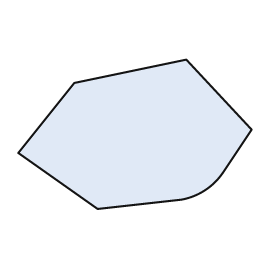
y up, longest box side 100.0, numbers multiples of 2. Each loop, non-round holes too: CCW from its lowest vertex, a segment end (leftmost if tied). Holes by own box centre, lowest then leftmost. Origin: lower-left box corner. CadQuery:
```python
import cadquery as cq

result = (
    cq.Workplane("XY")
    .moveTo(34.0, 0.0)
    .lineTo(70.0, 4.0)
    .threePointArc((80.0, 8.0), (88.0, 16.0))
    .lineTo(100.0, 34.0)
    .lineTo(72.0, 64.0)
    .lineTo(24.0, 54.0)
    .lineTo(0.0, 24.0)
    .close()
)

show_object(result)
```